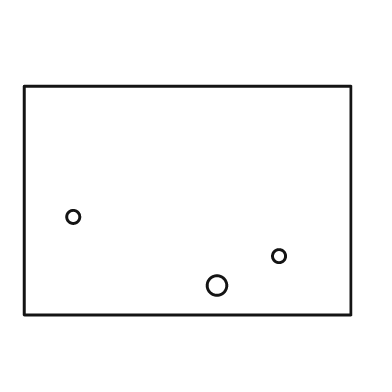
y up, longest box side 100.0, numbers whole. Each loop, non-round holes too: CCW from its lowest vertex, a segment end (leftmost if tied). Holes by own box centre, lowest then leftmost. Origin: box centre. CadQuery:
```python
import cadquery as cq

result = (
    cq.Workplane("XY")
    .moveTo(-50.0, -35.0)
    .lineTo(50.0, -35.0)
    .lineTo(50.0, 35.0)
    .lineTo(-50.0, 35.0)
    .close()
    .moveTo(9.0, -26.0)
    .circle(3.0)
    .moveTo(28.0, -17.0)
    .circle(2.0)
    .moveTo(-35.0, -5.0)
    .circle(2.0)
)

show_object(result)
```